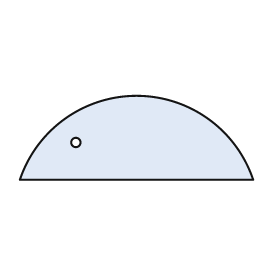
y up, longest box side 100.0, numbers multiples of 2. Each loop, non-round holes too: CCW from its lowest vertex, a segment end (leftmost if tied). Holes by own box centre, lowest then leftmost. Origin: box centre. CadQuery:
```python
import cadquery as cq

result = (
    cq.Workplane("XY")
    .moveTo(-50.0, -18.0)
    .lineTo(50.0, -18.0)
    .threePointArc((0.0, 18.0), (-50.0, -18.0))
    .close()
    .moveTo(-26.0, -2.0)
    .circle(2.0)
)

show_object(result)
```